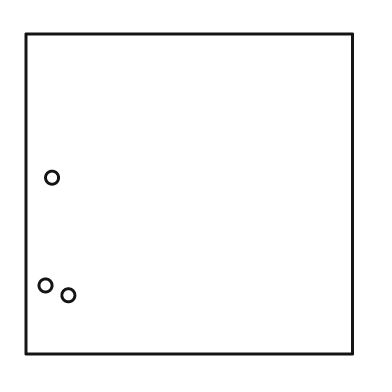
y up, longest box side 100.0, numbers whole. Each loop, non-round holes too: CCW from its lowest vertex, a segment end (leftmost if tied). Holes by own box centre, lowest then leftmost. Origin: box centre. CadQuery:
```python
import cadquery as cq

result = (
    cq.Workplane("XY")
    .moveTo(-50.0, -49.0)
    .lineTo(50.0, -49.0)
    .lineTo(50.0, 49.0)
    .lineTo(-50.0, 49.0)
    .close()
    .moveTo(-37.0, -31.0)
    .circle(2.0)
    .moveTo(-44.0, -28.0)
    .circle(2.0)
    .moveTo(-42.0, 5.0)
    .circle(2.0)
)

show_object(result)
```